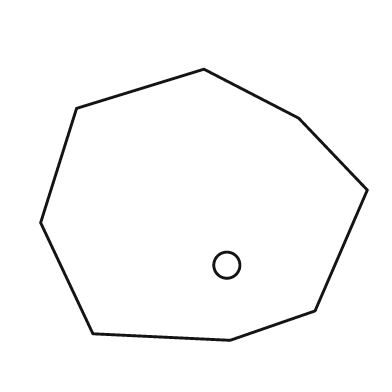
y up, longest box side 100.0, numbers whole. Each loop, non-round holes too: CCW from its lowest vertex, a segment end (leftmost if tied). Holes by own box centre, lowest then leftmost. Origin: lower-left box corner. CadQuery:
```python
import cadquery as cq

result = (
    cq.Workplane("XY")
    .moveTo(58.0, 0.0)
    .lineTo(84.0, 9.0)
    .lineTo(100.0, 46.0)
    .lineTo(79.0, 68.0)
    .lineTo(50.0, 83.0)
    .lineTo(11.0, 71.0)
    .lineTo(0.0, 36.0)
    .lineTo(16.0, 2.0)
    .close()
    .moveTo(57.0, 23.0)
    .circle(4.0)
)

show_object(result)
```